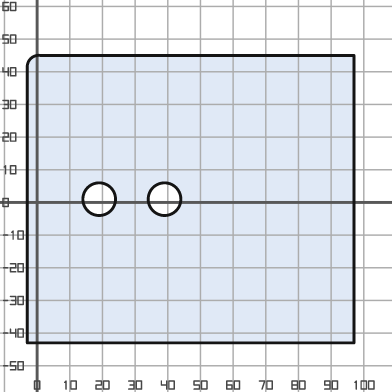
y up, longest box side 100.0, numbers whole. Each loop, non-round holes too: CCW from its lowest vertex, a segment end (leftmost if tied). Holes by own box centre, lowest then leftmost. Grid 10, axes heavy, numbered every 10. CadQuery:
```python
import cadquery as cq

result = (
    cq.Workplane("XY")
    .moveTo(-3.0, -43.0)
    .lineTo(97.0, -43.0)
    .lineTo(97.0, 45.0)
    .lineTo(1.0, 45.0)
    .threePointArc((-2.0, 44.0), (-3.0, 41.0))
    .close()
    .moveTo(19.0, 1.0)
    .circle(5.0)
    .moveTo(39.0, 1.0)
    .circle(5.0)
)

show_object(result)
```